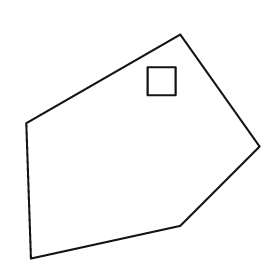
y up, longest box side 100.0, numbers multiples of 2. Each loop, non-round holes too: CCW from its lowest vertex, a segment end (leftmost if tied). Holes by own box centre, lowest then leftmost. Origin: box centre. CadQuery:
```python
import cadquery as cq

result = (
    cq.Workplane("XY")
    .moveTo(-48.0, -48.0)
    .lineTo(16.0, -34.0)
    .lineTo(50.0, 0.0)
    .lineTo(16.0, 48.0)
    .lineTo(-50.0, 10.0)
    .close()
    .moveTo(2.0, 22.0)
    .lineTo(14.0, 22.0)
    .lineTo(14.0, 34.0)
    .lineTo(2.0, 34.0)
    .close()
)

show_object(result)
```